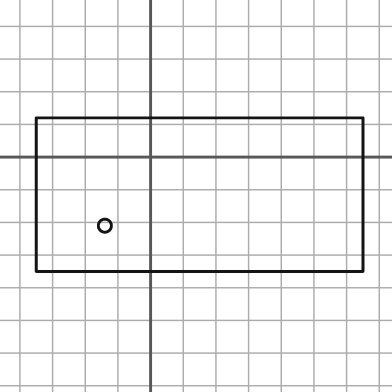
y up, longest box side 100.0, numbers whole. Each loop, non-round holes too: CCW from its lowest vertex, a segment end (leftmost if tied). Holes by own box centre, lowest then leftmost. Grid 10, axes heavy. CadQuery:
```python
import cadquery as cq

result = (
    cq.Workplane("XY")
    .moveTo(-35.0, -35.0)
    .lineTo(65.0, -35.0)
    .lineTo(65.0, 12.0)
    .lineTo(-35.0, 12.0)
    .close()
    .moveTo(-14.0, -21.0)
    .circle(2.0)
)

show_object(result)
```